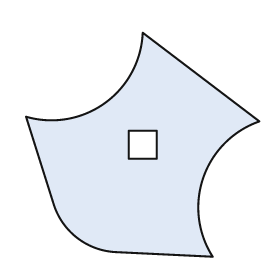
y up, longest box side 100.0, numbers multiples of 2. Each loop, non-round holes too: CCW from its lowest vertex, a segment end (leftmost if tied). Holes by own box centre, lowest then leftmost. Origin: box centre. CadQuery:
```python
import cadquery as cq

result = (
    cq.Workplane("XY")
    .moveTo(30.0, -48.0)
    .threePointArc((26.0, -14.0), (50.0, 10.0))
    .lineTo(0.0, 48.0)
    .threePointArc((-16.0, 18.0), (-50.0, 12.0))
    .lineTo(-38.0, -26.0)
    .threePointArc((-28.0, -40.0), (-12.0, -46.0))
    .close()
    .moveTo(-6.0, -6.0)
    .lineTo(6.0, -6.0)
    .lineTo(6.0, 6.0)
    .lineTo(-6.0, 6.0)
    .close()
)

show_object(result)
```